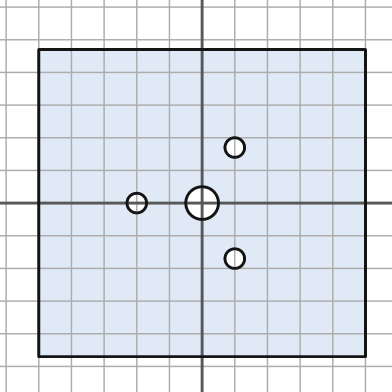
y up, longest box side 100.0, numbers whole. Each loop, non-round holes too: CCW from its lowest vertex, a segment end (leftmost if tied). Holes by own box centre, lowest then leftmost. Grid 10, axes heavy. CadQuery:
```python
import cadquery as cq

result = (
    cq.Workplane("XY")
    .moveTo(-50.0, -47.0)
    .lineTo(50.0, -47.0)
    .lineTo(50.0, 47.0)
    .lineTo(-50.0, 47.0)
    .close()
    .moveTo(10.0, -17.0)
    .circle(3.0)
    .moveTo(-20.0, 0.0)
    .circle(3.0)
    .moveTo(0.0, 0.0)
    .circle(5.0)
    .moveTo(10.0, 17.0)
    .circle(3.0)
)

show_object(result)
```